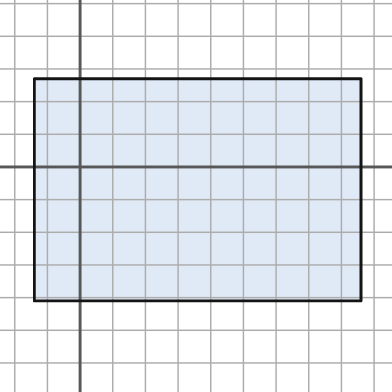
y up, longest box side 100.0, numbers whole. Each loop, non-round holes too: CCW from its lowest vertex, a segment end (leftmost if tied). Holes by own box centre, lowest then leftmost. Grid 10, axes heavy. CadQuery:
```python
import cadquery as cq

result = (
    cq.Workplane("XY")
    .moveTo(-14.0, -41.0)
    .lineTo(86.0, -41.0)
    .lineTo(86.0, 27.0)
    .lineTo(-14.0, 27.0)
    .close()
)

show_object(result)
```